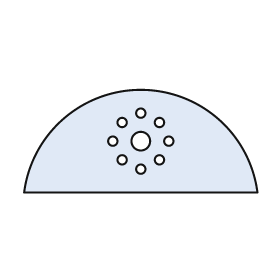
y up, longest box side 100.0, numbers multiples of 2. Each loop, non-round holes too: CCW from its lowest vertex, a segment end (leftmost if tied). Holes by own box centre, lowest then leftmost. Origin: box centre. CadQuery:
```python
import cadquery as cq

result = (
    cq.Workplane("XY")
    .moveTo(-50.0, -22.0)
    .lineTo(50.0, -22.0)
    .threePointArc((0.0, 22.0), (-50.0, -22.0))
    .close()
    .moveTo(0.0, -12.0)
    .circle(2.0)
    .moveTo(-8.0, -8.0)
    .circle(2.0)
    .moveTo(8.0, -8.0)
    .circle(2.0)
    .moveTo(-12.0, 0.0)
    .circle(2.0)
    .moveTo(0.0, 0.0)
    .circle(4.0)
    .moveTo(12.0, 0.0)
    .circle(2.0)
    .moveTo(-8.0, 8.0)
    .circle(2.0)
    .moveTo(8.0, 8.0)
    .circle(2.0)
    .moveTo(0.0, 12.0)
    .circle(2.0)
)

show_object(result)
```